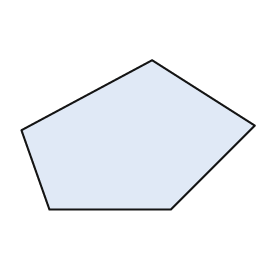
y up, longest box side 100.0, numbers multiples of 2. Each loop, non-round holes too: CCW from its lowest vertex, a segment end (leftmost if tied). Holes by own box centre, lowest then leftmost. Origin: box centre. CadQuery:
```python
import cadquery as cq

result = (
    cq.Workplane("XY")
    .moveTo(-38.0, -32.0)
    .lineTo(14.0, -32.0)
    .lineTo(50.0, 4.0)
    .lineTo(6.0, 32.0)
    .lineTo(-50.0, 2.0)
    .close()
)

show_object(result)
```